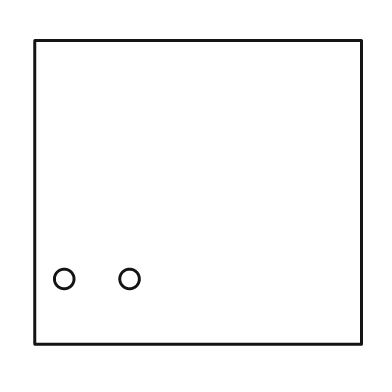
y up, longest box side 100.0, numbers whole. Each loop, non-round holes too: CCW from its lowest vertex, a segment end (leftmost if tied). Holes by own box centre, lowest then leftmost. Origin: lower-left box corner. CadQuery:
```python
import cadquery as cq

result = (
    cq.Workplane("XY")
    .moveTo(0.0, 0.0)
    .lineTo(100.0, 0.0)
    .lineTo(100.0, 93.0)
    .lineTo(0.0, 93.0)
    .close()
    .moveTo(9.0, 20.0)
    .circle(3.0)
    .moveTo(29.0, 20.0)
    .circle(3.0)
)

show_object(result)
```